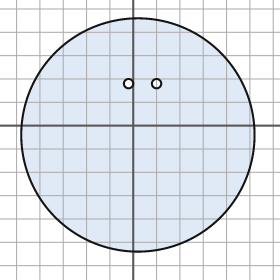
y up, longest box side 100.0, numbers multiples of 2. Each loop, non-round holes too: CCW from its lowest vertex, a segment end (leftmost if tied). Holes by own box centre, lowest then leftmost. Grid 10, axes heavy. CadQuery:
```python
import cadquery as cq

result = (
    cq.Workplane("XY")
    .moveTo(2.0, -4.0)
    .circle(50.0)
    .moveTo(-2.0, 18.0)
    .circle(2.0)
    .moveTo(10.0, 18.0)
    .circle(2.0)
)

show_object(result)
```